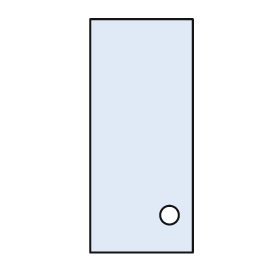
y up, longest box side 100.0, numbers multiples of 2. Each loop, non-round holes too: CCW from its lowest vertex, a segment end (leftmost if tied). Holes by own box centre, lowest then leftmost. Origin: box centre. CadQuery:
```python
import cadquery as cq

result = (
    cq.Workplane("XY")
    .moveTo(-22.0, -50.0)
    .lineTo(22.0, -50.0)
    .lineTo(22.0, 50.0)
    .lineTo(-22.0, 50.0)
    .close()
    .moveTo(12.0, -34.0)
    .circle(4.0)
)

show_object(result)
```